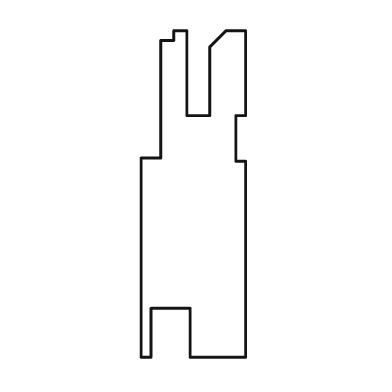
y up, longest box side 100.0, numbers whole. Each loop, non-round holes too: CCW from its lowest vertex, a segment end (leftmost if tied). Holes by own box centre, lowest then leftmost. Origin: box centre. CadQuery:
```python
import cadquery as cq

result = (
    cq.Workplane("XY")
    .moveTo(-16.0, -50.0)
    .lineTo(-13.0, -50.0)
    .lineTo(-13.0, -35.0)
    .lineTo(-1.0, -35.0)
    .lineTo(-1.0, -50.0)
    .lineTo(16.0, -50.0)
    .lineTo(16.0, 10.0)
    .lineTo(13.0, 10.0)
    .lineTo(13.0, 24.0)
    .lineTo(16.0, 24.0)
    .lineTo(16.0, 50.0)
    .lineTo(10.0, 50.0)
    .lineTo(5.0, 45.0)
    .lineTo(5.0, 24.0)
    .lineTo(-2.0, 24.0)
    .lineTo(-2.0, 50.0)
    .lineTo(-6.0, 50.0)
    .lineTo(-6.0, 47.0)
    .lineTo(-10.0, 47.0)
    .lineTo(-10.0, 11.0)
    .lineTo(-16.0, 11.0)
    .close()
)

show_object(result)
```